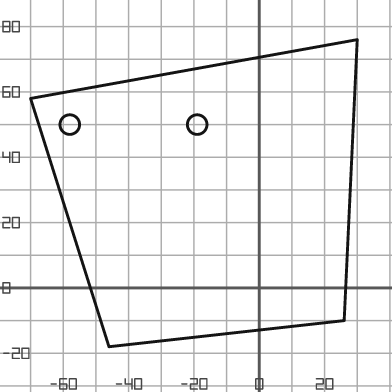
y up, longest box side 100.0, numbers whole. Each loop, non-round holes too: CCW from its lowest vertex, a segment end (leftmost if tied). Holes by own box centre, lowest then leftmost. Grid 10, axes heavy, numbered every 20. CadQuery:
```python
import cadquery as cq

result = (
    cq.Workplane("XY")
    .moveTo(-46.0, -18.0)
    .lineTo(26.0, -10.0)
    .lineTo(30.0, 76.0)
    .lineTo(-70.0, 58.0)
    .close()
    .moveTo(-58.0, 50.0)
    .circle(3.0)
    .moveTo(-19.0, 50.0)
    .circle(3.0)
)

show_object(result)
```